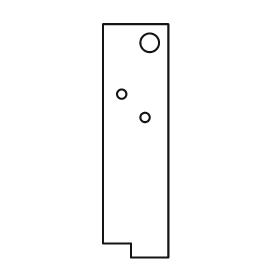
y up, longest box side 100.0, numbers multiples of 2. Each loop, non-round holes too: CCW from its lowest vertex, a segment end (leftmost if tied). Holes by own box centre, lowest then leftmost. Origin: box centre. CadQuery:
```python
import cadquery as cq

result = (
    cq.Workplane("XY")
    .moveTo(-2.0, -50.0)
    .lineTo(14.0, -50.0)
    .lineTo(14.0, 50.0)
    .lineTo(-14.0, 50.0)
    .lineTo(-14.0, -44.0)
    .lineTo(-2.0, -44.0)
    .close()
    .moveTo(4.0, 10.0)
    .circle(2.0)
    .moveTo(-6.0, 20.0)
    .circle(2.0)
    .moveTo(6.0, 42.0)
    .circle(4.0)
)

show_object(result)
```